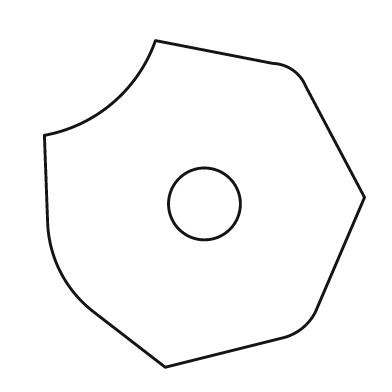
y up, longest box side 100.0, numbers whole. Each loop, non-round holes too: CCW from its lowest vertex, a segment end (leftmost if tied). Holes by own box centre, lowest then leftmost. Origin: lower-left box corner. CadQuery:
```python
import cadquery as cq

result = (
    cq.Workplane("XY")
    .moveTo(37.0, 0.0)
    .lineTo(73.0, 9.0)
    .threePointArc((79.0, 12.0), (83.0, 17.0))
    .lineTo(98.0, 52.0)
    .lineTo(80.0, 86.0)
    .threePointArc((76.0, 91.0), (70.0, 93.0))
    .lineTo(34.0, 100.0)
    .threePointArc((21.0, 81.0), (0.0, 71.0))
    .lineTo(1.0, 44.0)
    .threePointArc((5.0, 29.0), (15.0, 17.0))
    .close()
    .moveTo(49.0, 50.0)
    .circle(11.0)
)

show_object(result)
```